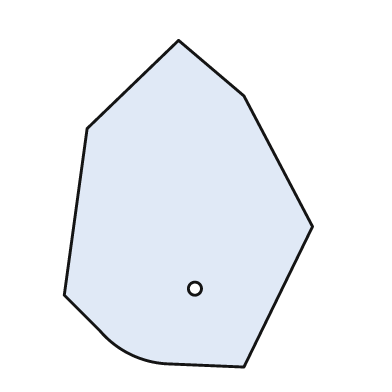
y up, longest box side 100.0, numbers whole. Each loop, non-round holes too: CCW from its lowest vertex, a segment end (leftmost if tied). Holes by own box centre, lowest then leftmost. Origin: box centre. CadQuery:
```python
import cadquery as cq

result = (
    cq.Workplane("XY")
    .moveTo(17.0, -50.0)
    .lineTo(38.0, -7.0)
    .lineTo(17.0, 33.0)
    .lineTo(-3.0, 50.0)
    .lineTo(-31.0, 23.0)
    .lineTo(-38.0, -28.0)
    .lineTo(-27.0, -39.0)
    .threePointArc((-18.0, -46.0), (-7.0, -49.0))
    .close()
    .moveTo(2.0, -26.0)
    .circle(2.0)
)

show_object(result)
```